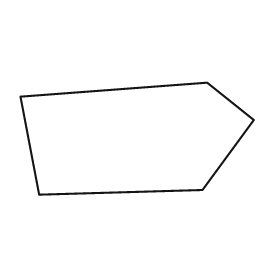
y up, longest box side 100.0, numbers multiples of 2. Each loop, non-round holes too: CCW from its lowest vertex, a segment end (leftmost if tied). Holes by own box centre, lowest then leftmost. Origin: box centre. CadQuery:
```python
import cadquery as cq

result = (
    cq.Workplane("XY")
    .moveTo(-42.0, -24.0)
    .lineTo(28.0, -22.0)
    .lineTo(50.0, 8.0)
    .lineTo(30.0, 24.0)
    .lineTo(-50.0, 18.0)
    .close()
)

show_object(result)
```